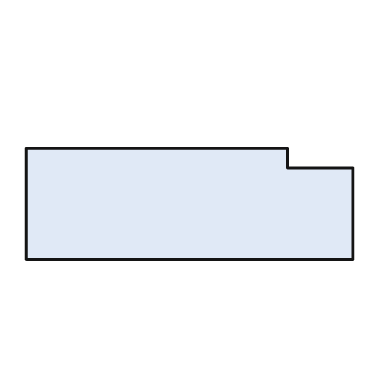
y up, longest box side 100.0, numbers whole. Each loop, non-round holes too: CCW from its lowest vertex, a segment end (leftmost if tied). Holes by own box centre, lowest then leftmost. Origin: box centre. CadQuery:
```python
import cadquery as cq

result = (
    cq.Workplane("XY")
    .moveTo(-50.0, -17.0)
    .lineTo(50.0, -17.0)
    .lineTo(50.0, 11.0)
    .lineTo(30.0, 11.0)
    .lineTo(30.0, 17.0)
    .lineTo(-50.0, 17.0)
    .close()
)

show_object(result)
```